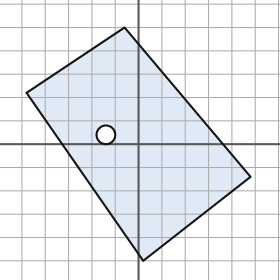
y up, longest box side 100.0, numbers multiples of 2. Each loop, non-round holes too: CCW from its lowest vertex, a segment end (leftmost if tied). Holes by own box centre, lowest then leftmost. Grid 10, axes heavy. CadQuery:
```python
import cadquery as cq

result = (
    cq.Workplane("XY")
    .moveTo(2.0, -50.0)
    .lineTo(48.0, -14.0)
    .lineTo(-6.0, 50.0)
    .lineTo(-48.0, 22.0)
    .close()
    .moveTo(-14.0, 4.0)
    .circle(4.0)
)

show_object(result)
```